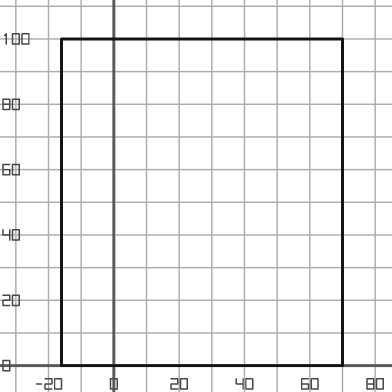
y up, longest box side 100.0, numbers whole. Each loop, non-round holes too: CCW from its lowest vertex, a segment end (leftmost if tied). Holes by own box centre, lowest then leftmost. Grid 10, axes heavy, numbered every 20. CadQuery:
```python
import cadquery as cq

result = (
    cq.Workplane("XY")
    .moveTo(-16.0, 0.0)
    .lineTo(70.0, 0.0)
    .lineTo(70.0, 100.0)
    .lineTo(-16.0, 100.0)
    .close()
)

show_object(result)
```